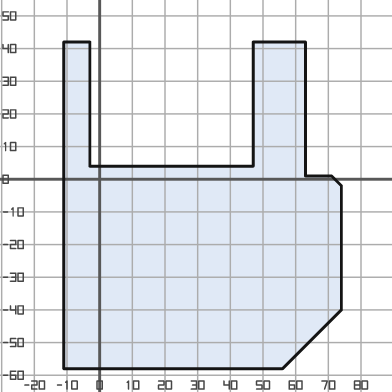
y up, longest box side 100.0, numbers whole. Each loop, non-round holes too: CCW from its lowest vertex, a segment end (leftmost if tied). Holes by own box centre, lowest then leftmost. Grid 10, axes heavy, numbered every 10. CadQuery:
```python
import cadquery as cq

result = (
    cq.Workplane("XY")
    .moveTo(-11.0, -58.0)
    .lineTo(56.0, -58.0)
    .lineTo(74.0, -40.0)
    .lineTo(74.0, -2.0)
    .lineTo(71.0, 1.0)
    .lineTo(63.0, 1.0)
    .lineTo(63.0, 42.0)
    .lineTo(47.0, 42.0)
    .lineTo(47.0, 4.0)
    .lineTo(-3.0, 4.0)
    .lineTo(-3.0, 42.0)
    .lineTo(-11.0, 42.0)
    .close()
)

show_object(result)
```